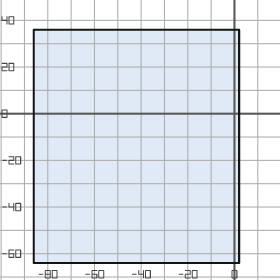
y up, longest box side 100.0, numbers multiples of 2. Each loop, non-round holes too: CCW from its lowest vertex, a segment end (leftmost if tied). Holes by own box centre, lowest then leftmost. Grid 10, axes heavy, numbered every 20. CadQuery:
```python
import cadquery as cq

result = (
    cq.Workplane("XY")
    .moveTo(-86.0, -64.0)
    .lineTo(2.0, -64.0)
    .lineTo(2.0, 36.0)
    .lineTo(-86.0, 36.0)
    .close()
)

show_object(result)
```